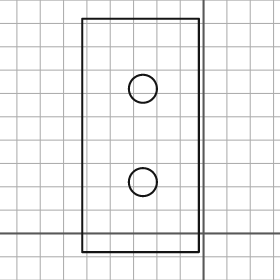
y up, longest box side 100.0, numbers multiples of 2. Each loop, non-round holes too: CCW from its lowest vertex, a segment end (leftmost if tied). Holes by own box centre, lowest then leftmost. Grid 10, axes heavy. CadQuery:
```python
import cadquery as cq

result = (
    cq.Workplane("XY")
    .moveTo(-52.0, -8.0)
    .lineTo(-2.0, -8.0)
    .lineTo(-2.0, 92.0)
    .lineTo(-52.0, 92.0)
    .close()
    .moveTo(-26.0, 22.0)
    .circle(6.0)
    .moveTo(-26.0, 62.0)
    .circle(6.0)
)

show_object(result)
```